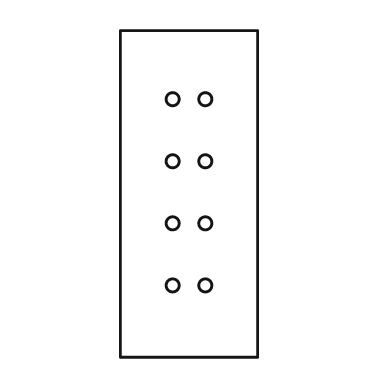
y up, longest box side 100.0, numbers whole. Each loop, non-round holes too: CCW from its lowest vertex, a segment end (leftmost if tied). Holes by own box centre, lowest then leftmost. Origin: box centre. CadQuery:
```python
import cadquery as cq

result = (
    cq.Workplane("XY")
    .moveTo(-21.0, -50.0)
    .lineTo(21.0, -50.0)
    .lineTo(21.0, 50.0)
    .lineTo(-21.0, 50.0)
    .close()
    .moveTo(-5.0, -28.0)
    .circle(2.0)
    .moveTo(5.0, -28.0)
    .circle(2.0)
    .moveTo(-5.0, -9.0)
    .circle(2.0)
    .moveTo(5.0, -9.0)
    .circle(2.0)
    .moveTo(-5.0, 10.0)
    .circle(2.0)
    .moveTo(5.0, 10.0)
    .circle(2.0)
    .moveTo(-5.0, 29.0)
    .circle(2.0)
    .moveTo(5.0, 29.0)
    .circle(2.0)
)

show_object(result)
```